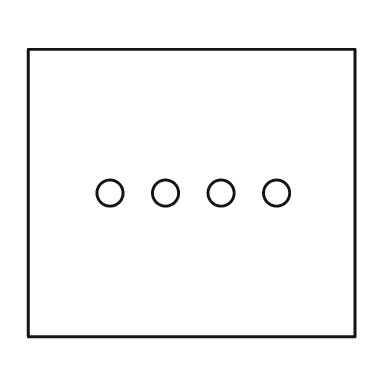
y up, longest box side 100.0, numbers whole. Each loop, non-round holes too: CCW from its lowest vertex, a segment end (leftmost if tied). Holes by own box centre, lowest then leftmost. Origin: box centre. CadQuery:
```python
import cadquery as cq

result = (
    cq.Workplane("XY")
    .moveTo(-50.0, -44.0)
    .lineTo(50.0, -44.0)
    .lineTo(50.0, 44.0)
    .lineTo(-50.0, 44.0)
    .close()
    .moveTo(-25.0, 0.0)
    .circle(4.0)
    .moveTo(-8.0, 0.0)
    .circle(4.0)
    .moveTo(9.0, 0.0)
    .circle(4.0)
    .moveTo(26.0, 0.0)
    .circle(4.0)
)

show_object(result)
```